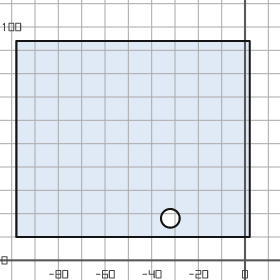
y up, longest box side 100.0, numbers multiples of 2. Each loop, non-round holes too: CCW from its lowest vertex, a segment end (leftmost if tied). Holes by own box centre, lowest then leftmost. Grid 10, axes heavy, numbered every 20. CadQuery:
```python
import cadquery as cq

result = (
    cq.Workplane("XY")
    .moveTo(-98.0, 10.0)
    .lineTo(2.0, 10.0)
    .lineTo(2.0, 94.0)
    .lineTo(-98.0, 94.0)
    .close()
    .moveTo(-32.0, 18.0)
    .circle(4.0)
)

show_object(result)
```